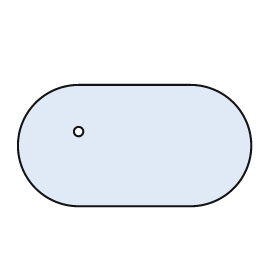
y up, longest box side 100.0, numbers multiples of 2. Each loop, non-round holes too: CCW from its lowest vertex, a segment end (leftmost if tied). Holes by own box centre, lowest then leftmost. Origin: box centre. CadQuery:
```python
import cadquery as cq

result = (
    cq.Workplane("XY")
    .moveTo(-24.0, -26.0)
    .lineTo(24.0, -26.0)
    .threePointArc((50.0, 0.0), (24.0, 26.0))
    .lineTo(-24.0, 26.0)
    .threePointArc((-50.0, 0.0), (-24.0, -26.0))
    .close()
    .moveTo(-24.0, 6.0)
    .circle(2.0)
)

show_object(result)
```